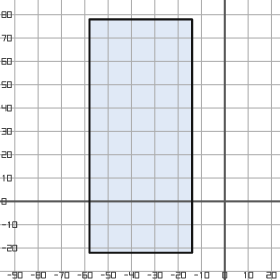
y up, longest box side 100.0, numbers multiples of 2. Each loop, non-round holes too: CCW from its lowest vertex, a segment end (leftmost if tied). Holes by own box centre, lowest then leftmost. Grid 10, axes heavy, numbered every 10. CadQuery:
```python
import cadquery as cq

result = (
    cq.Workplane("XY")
    .moveTo(-58.0, -22.0)
    .lineTo(-14.0, -22.0)
    .lineTo(-14.0, 78.0)
    .lineTo(-58.0, 78.0)
    .close()
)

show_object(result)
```